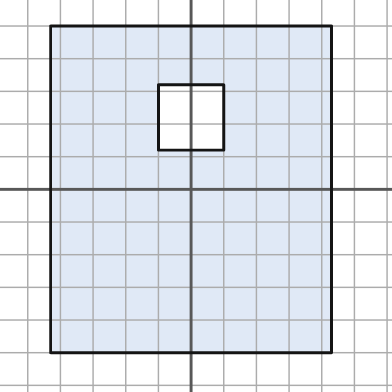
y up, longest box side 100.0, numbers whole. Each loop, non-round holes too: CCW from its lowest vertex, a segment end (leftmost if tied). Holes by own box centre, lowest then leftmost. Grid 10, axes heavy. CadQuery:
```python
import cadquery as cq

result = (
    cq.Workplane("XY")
    .moveTo(-43.0, -50.0)
    .lineTo(43.0, -50.0)
    .lineTo(43.0, 50.0)
    .lineTo(-43.0, 50.0)
    .close()
    .moveTo(-10.0, 12.0)
    .lineTo(10.0, 12.0)
    .lineTo(10.0, 32.0)
    .lineTo(-10.0, 32.0)
    .close()
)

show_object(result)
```